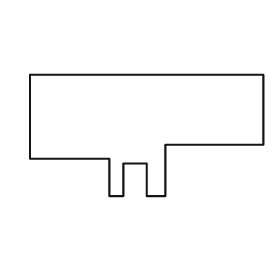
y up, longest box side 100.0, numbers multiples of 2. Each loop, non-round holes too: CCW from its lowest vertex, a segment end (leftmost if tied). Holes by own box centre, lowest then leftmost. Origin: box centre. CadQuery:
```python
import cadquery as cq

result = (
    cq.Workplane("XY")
    .moveTo(-16.0, -26.0)
    .lineTo(-10.0, -26.0)
    .lineTo(-10.0, -12.0)
    .lineTo(0.0, -12.0)
    .lineTo(0.0, -26.0)
    .lineTo(8.0, -26.0)
    .lineTo(8.0, -4.0)
    .lineTo(50.0, -4.0)
    .lineTo(50.0, 26.0)
    .lineTo(-50.0, 26.0)
    .lineTo(-50.0, -10.0)
    .lineTo(-16.0, -10.0)
    .close()
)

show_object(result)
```